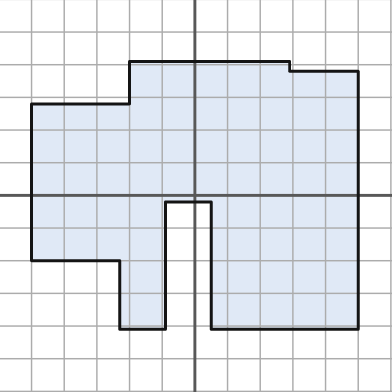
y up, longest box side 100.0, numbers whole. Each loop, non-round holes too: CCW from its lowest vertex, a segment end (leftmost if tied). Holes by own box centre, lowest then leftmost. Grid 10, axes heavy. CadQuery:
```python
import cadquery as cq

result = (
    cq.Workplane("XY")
    .moveTo(-23.0, -41.0)
    .lineTo(-9.0, -41.0)
    .lineTo(-9.0, -2.0)
    .lineTo(5.0, -2.0)
    .lineTo(5.0, -41.0)
    .lineTo(50.0, -41.0)
    .lineTo(50.0, 38.0)
    .lineTo(29.0, 38.0)
    .lineTo(29.0, 41.0)
    .lineTo(-20.0, 41.0)
    .lineTo(-20.0, 28.0)
    .lineTo(-50.0, 28.0)
    .lineTo(-50.0, -20.0)
    .lineTo(-23.0, -20.0)
    .close()
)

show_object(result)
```